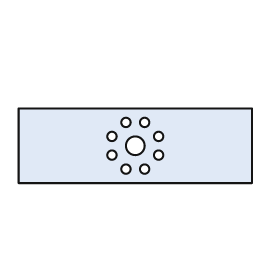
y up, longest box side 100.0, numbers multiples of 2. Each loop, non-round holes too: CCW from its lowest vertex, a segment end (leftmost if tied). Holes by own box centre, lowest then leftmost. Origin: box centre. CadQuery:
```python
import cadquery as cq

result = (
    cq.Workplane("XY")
    .moveTo(-50.0, -16.0)
    .lineTo(50.0, -16.0)
    .lineTo(50.0, 16.0)
    .lineTo(-50.0, 16.0)
    .close()
    .moveTo(-4.0, -10.0)
    .circle(2.0)
    .moveTo(4.0, -10.0)
    .circle(2.0)
    .moveTo(-10.0, -4.0)
    .circle(2.0)
    .moveTo(10.0, -4.0)
    .circle(2.0)
    .moveTo(0.0, 0.0)
    .circle(4.0)
    .moveTo(-10.0, 4.0)
    .circle(2.0)
    .moveTo(10.0, 4.0)
    .circle(2.0)
    .moveTo(-4.0, 10.0)
    .circle(2.0)
    .moveTo(4.0, 10.0)
    .circle(2.0)
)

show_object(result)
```